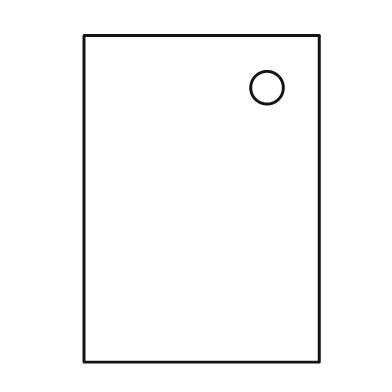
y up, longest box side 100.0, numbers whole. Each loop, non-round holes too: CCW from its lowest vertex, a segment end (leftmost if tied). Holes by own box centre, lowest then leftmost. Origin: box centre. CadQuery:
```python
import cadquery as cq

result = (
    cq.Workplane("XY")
    .moveTo(-36.0, -50.0)
    .lineTo(36.0, -50.0)
    .lineTo(36.0, 50.0)
    .lineTo(-36.0, 50.0)
    .close()
    .moveTo(20.0, 34.0)
    .circle(5.0)
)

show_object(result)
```